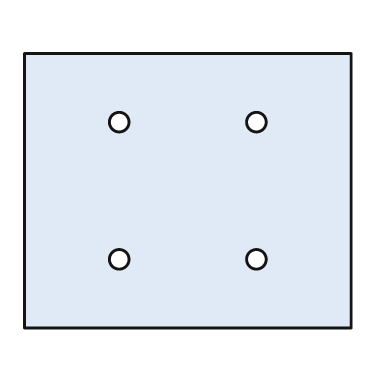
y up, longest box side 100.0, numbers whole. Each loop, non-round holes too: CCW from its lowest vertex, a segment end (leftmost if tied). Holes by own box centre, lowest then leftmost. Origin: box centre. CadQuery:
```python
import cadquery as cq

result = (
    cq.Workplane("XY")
    .moveTo(-50.0, -42.0)
    .lineTo(50.0, -42.0)
    .lineTo(50.0, 42.0)
    .lineTo(-50.0, 42.0)
    .close()
    .moveTo(-21.0, -21.0)
    .circle(3.0)
    .moveTo(21.0, -21.0)
    .circle(3.0)
    .moveTo(-21.0, 21.0)
    .circle(3.0)
    .moveTo(21.0, 21.0)
    .circle(3.0)
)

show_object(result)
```